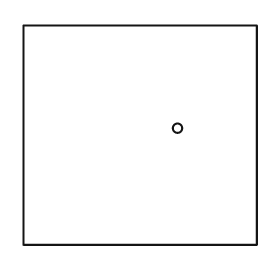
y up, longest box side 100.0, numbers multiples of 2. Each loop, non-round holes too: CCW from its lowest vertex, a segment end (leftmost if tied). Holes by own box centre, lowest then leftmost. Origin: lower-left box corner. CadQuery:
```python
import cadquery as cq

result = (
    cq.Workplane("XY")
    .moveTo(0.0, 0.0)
    .lineTo(100.0, 0.0)
    .lineTo(100.0, 94.0)
    .lineTo(0.0, 94.0)
    .close()
    .moveTo(66.0, 50.0)
    .circle(2.0)
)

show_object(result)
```